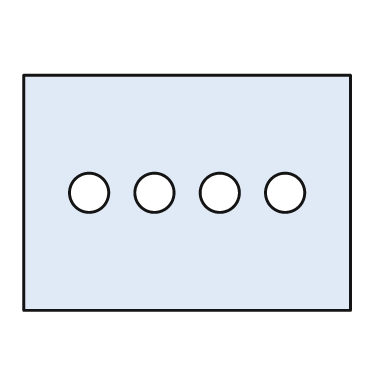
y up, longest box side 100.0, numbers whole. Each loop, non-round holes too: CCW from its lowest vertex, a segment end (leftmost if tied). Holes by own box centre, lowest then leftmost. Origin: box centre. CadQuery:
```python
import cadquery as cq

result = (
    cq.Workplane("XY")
    .moveTo(-50.0, -36.0)
    .lineTo(50.0, -36.0)
    .lineTo(50.0, 36.0)
    .lineTo(-50.0, 36.0)
    .close()
    .moveTo(-30.0, 0.0)
    .circle(6.0)
    .moveTo(-10.0, 0.0)
    .circle(6.0)
    .moveTo(10.0, 0.0)
    .circle(6.0)
    .moveTo(30.0, 0.0)
    .circle(6.0)
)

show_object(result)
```